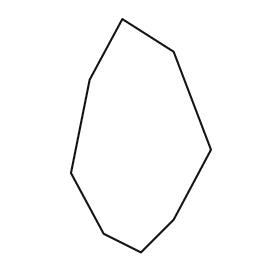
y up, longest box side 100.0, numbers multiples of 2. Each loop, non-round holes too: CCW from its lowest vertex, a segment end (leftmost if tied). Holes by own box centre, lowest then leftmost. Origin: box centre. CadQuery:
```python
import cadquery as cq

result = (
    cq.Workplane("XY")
    .moveTo(0.0, -50.0)
    .lineTo(14.0, -36.0)
    .lineTo(30.0, -6.0)
    .lineTo(14.0, 36.0)
    .lineTo(-8.0, 50.0)
    .lineTo(-22.0, 24.0)
    .lineTo(-30.0, -16.0)
    .lineTo(-16.0, -42.0)
    .close()
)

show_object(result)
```